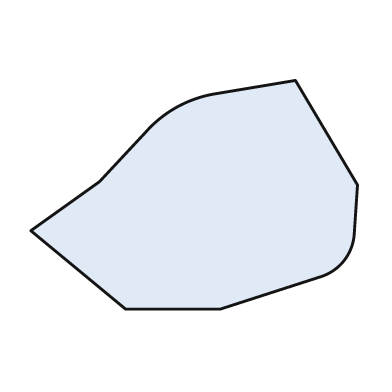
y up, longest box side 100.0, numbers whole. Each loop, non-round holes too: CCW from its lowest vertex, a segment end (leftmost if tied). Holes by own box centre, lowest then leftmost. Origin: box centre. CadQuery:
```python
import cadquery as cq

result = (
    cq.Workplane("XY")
    .moveTo(-21.0, -35.0)
    .lineTo(8.0, -35.0)
    .lineTo(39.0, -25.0)
    .threePointArc((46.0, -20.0), (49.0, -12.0))
    .lineTo(50.0, 3.0)
    .lineTo(31.0, 35.0)
    .lineTo(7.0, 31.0)
    .threePointArc((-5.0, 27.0), (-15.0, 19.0))
    .lineTo(-29.0, 4.0)
    .lineTo(-50.0, -11.0)
    .close()
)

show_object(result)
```